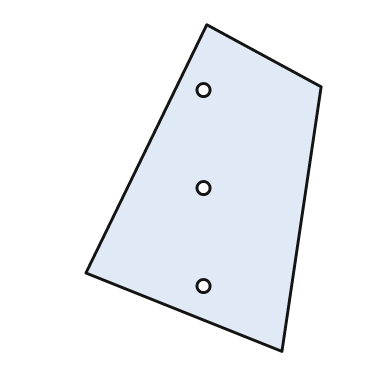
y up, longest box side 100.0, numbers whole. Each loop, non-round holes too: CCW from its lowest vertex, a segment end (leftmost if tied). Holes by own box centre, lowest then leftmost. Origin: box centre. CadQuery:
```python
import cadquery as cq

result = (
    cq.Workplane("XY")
    .moveTo(24.0, -50.0)
    .lineTo(36.0, 31.0)
    .lineTo(1.0, 50.0)
    .lineTo(-36.0, -26.0)
    .close()
    .moveTo(0.0, -30.0)
    .circle(2.0)
    .moveTo(0.0, 0.0)
    .circle(2.0)
    .moveTo(0.0, 30.0)
    .circle(2.0)
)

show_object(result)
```